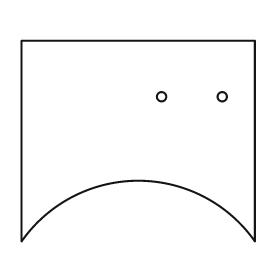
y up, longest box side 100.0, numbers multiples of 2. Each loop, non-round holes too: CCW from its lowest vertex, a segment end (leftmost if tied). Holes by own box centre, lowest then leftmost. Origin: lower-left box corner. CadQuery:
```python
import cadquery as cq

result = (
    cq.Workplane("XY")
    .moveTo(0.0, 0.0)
    .threePointArc((50.0, 26.0), (100.0, 0.0))
    .lineTo(100.0, 86.0)
    .lineTo(0.0, 86.0)
    .close()
    .moveTo(60.0, 62.0)
    .circle(2.0)
    .moveTo(86.0, 62.0)
    .circle(2.0)
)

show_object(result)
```